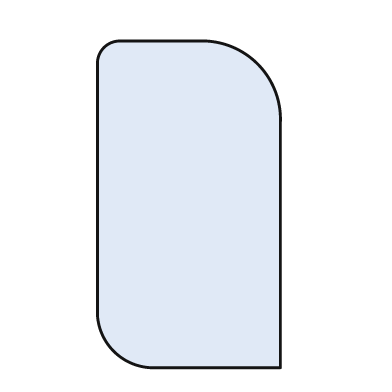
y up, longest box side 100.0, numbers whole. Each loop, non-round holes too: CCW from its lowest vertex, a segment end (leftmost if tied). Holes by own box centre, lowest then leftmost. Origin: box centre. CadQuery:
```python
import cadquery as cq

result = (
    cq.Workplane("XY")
    .moveTo(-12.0, -50.0)
    .lineTo(28.0, -50.0)
    .lineTo(28.0, 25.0)
    .threePointArc((21.0, 43.0), (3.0, 50.0))
    .lineTo(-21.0, 50.0)
    .threePointArc((-26.0, 48.0), (-28.0, 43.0))
    .lineTo(-28.0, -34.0)
    .threePointArc((-23.0, -45.0), (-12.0, -50.0))
    .close()
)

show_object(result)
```